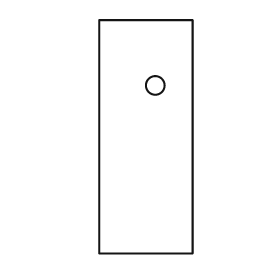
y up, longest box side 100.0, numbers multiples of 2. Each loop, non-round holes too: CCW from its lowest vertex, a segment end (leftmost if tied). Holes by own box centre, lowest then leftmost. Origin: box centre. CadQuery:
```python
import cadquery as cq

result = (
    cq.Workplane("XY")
    .moveTo(-20.0, -50.0)
    .lineTo(20.0, -50.0)
    .lineTo(20.0, 50.0)
    .lineTo(-20.0, 50.0)
    .close()
    .moveTo(4.0, 22.0)
    .circle(4.0)
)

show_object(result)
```